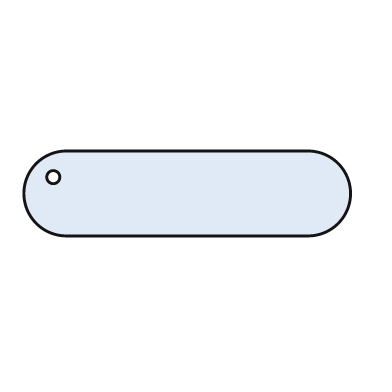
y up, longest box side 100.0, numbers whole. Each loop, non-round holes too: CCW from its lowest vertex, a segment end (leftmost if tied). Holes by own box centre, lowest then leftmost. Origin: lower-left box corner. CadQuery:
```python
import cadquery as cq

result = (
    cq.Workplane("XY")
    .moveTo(13.0, 0.0)
    .lineTo(87.0, 0.0)
    .threePointArc((100.0, 13.0), (87.0, 26.0))
    .lineTo(13.0, 26.0)
    .threePointArc((0.0, 13.0), (13.0, 0.0))
    .close()
    .moveTo(9.0, 18.0)
    .circle(2.0)
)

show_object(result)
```